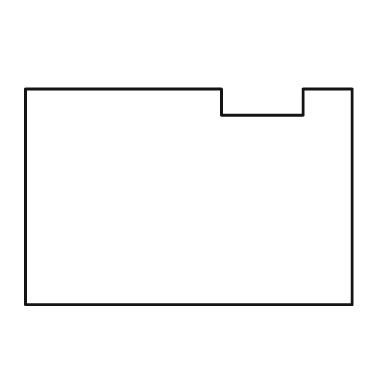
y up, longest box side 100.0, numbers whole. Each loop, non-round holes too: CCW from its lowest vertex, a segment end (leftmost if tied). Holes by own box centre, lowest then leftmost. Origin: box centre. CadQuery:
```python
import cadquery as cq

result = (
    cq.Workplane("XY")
    .moveTo(-50.0, -33.0)
    .lineTo(50.0, -33.0)
    .lineTo(50.0, 33.0)
    .lineTo(35.0, 33.0)
    .lineTo(35.0, 25.0)
    .lineTo(10.0, 25.0)
    .lineTo(10.0, 33.0)
    .lineTo(-50.0, 33.0)
    .close()
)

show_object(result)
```